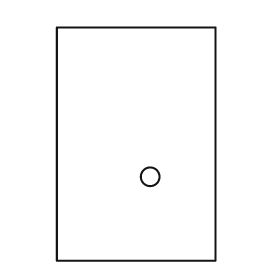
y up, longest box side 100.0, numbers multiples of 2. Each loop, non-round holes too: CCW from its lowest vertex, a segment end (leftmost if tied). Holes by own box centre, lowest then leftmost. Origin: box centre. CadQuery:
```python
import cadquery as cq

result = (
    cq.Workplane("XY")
    .moveTo(-34.0, -50.0)
    .lineTo(34.0, -50.0)
    .lineTo(34.0, 50.0)
    .lineTo(-34.0, 50.0)
    .close()
    .moveTo(6.0, -14.0)
    .circle(4.0)
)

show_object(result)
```